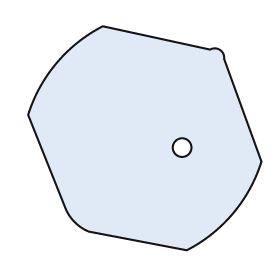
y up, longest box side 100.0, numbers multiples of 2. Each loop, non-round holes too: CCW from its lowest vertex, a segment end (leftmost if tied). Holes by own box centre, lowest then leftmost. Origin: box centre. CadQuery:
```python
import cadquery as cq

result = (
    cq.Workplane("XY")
    .moveTo(18.0, -48.0)
    .threePointArc((38.0, -32.0), (50.0, -10.0))
    .lineTo(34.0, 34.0)
    .threePointArc((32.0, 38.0), (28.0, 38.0))
    .lineTo(-18.0, 48.0)
    .threePointArc((-38.0, 32.0), (-50.0, 10.0))
    .lineTo(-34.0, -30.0)
    .threePointArc((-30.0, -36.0), (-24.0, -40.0))
    .close()
    .moveTo(16.0, -4.0)
    .circle(4.0)
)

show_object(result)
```